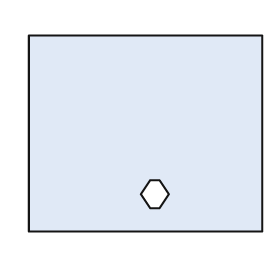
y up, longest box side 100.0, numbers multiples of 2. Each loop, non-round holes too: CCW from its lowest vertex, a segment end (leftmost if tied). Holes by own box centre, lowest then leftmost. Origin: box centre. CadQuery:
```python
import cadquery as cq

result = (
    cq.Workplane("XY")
    .moveTo(-50.0, -42.0)
    .lineTo(50.0, -42.0)
    .lineTo(50.0, 42.0)
    .lineTo(-50.0, 42.0)
    .close()
    .moveTo(2.0, -32.0)
    .lineTo(6.0, -32.0)
    .lineTo(10.0, -26.0)
    .lineTo(6.0, -20.0)
    .lineTo(2.0, -20.0)
    .lineTo(-2.0, -26.0)
    .close()
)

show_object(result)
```